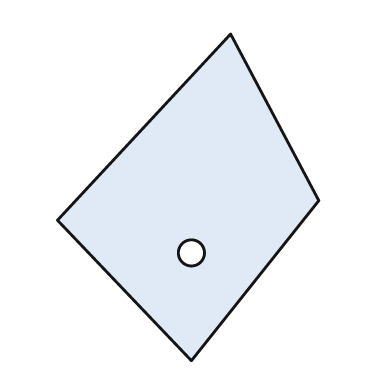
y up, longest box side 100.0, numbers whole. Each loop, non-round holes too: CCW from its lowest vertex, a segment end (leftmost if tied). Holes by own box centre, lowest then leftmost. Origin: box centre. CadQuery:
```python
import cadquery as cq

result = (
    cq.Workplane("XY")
    .moveTo(1.0, -50.0)
    .lineTo(40.0, -1.0)
    .lineTo(13.0, 50.0)
    .lineTo(-40.0, -7.0)
    .close()
    .moveTo(1.0, -17.0)
    .circle(4.0)
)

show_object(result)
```